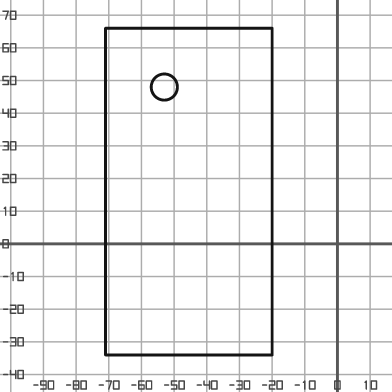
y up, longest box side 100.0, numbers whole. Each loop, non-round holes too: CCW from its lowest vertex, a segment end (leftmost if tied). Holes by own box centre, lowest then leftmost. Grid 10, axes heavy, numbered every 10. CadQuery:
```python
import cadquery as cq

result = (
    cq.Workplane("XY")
    .moveTo(-71.0, -34.0)
    .lineTo(-20.0, -34.0)
    .lineTo(-20.0, 66.0)
    .lineTo(-71.0, 66.0)
    .close()
    .moveTo(-53.0, 48.0)
    .circle(4.0)
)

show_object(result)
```